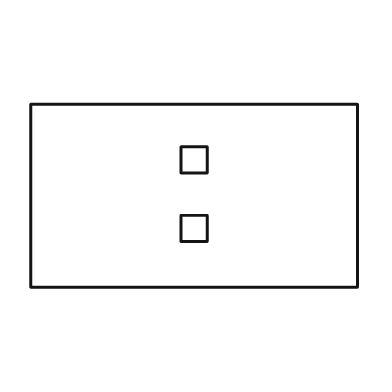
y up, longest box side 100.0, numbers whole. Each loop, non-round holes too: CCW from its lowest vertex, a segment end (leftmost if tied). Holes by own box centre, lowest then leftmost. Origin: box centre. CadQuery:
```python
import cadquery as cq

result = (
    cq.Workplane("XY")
    .moveTo(-50.0, -28.0)
    .lineTo(50.0, -28.0)
    .lineTo(50.0, 28.0)
    .lineTo(-50.0, 28.0)
    .close()
    .moveTo(-4.0, -14.0)
    .lineTo(4.0, -14.0)
    .lineTo(4.0, -6.0)
    .lineTo(-4.0, -6.0)
    .close()
    .moveTo(-4.0, 7.0)
    .lineTo(4.0, 7.0)
    .lineTo(4.0, 15.0)
    .lineTo(-4.0, 15.0)
    .close()
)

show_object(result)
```